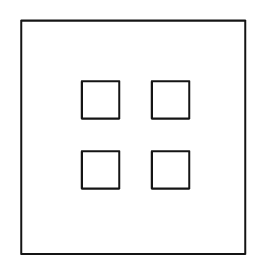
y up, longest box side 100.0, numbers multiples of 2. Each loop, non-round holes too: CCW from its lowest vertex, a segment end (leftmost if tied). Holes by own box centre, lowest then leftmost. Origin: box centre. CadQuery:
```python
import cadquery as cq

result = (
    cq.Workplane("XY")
    .moveTo(-48.0, -50.0)
    .lineTo(48.0, -50.0)
    .lineTo(48.0, 50.0)
    .lineTo(-48.0, 50.0)
    .close()
    .moveTo(-22.0, -22.0)
    .lineTo(-6.0, -22.0)
    .lineTo(-6.0, -6.0)
    .lineTo(-22.0, -6.0)
    .close()
    .moveTo(8.0, -22.0)
    .lineTo(24.0, -22.0)
    .lineTo(24.0, -6.0)
    .lineTo(8.0, -6.0)
    .close()
    .moveTo(-22.0, 8.0)
    .lineTo(-6.0, 8.0)
    .lineTo(-6.0, 24.0)
    .lineTo(-22.0, 24.0)
    .close()
    .moveTo(8.0, 8.0)
    .lineTo(24.0, 8.0)
    .lineTo(24.0, 24.0)
    .lineTo(8.0, 24.0)
    .close()
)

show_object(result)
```